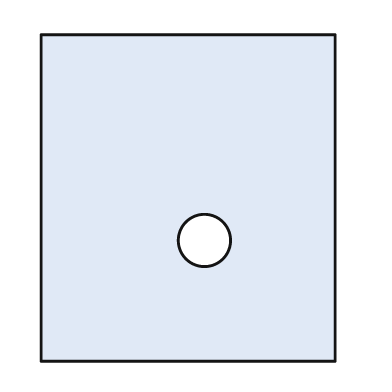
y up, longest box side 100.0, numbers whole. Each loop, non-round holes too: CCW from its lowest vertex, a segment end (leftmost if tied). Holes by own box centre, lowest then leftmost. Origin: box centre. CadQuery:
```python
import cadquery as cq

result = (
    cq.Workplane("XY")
    .moveTo(-45.0, -50.0)
    .lineTo(45.0, -50.0)
    .lineTo(45.0, 50.0)
    .lineTo(-45.0, 50.0)
    .close()
    .moveTo(5.0, -13.0)
    .circle(8.0)
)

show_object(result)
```